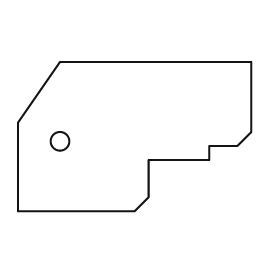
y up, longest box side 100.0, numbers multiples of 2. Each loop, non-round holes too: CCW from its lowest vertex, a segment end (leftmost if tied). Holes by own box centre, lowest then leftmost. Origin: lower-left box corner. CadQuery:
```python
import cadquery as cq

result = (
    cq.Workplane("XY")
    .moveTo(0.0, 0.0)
    .lineTo(50.0, 0.0)
    .lineTo(56.0, 6.0)
    .lineTo(56.0, 22.0)
    .lineTo(82.0, 22.0)
    .lineTo(82.0, 28.0)
    .lineTo(94.0, 28.0)
    .lineTo(100.0, 34.0)
    .lineTo(100.0, 64.0)
    .lineTo(18.0, 64.0)
    .lineTo(0.0, 38.0)
    .close()
    .moveTo(18.0, 30.0)
    .circle(4.0)
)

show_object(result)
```